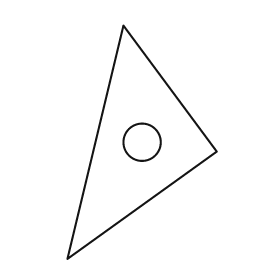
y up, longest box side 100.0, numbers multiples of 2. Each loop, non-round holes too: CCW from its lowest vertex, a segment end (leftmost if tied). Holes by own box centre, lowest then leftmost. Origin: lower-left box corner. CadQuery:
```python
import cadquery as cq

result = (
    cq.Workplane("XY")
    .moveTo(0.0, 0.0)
    .lineTo(64.0, 46.0)
    .lineTo(24.0, 100.0)
    .close()
    .moveTo(32.0, 50.0)
    .circle(8.0)
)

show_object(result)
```